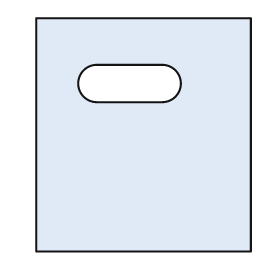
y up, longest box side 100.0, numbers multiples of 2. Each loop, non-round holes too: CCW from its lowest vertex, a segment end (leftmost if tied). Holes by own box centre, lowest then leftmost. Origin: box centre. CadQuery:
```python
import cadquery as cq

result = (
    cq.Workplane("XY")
    .moveTo(-46.0, -50.0)
    .lineTo(46.0, -50.0)
    .lineTo(46.0, 50.0)
    .lineTo(-46.0, 50.0)
    .close()
    .moveTo(-20.0, 14.0)
    .lineTo(8.0, 14.0)
    .threePointArc((16.0, 22.0), (8.0, 30.0))
    .lineTo(-20.0, 30.0)
    .threePointArc((-28.0, 22.0), (-20.0, 14.0))
    .close()
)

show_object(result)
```